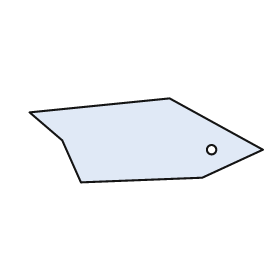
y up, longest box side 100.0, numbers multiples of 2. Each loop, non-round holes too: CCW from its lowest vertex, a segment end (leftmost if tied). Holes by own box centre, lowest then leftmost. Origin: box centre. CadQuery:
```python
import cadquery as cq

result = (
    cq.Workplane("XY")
    .moveTo(-28.0, -18.0)
    .lineTo(24.0, -16.0)
    .lineTo(50.0, -4.0)
    .lineTo(10.0, 18.0)
    .lineTo(-50.0, 12.0)
    .lineTo(-36.0, 0.0)
    .close()
    .moveTo(28.0, -4.0)
    .circle(2.0)
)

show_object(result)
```